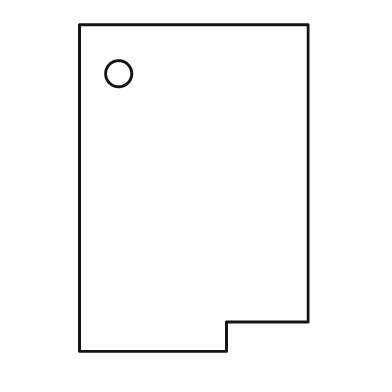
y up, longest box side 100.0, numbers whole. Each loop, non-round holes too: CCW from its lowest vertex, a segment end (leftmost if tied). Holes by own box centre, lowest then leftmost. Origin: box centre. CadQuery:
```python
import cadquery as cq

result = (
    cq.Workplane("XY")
    .moveTo(-35.0, -50.0)
    .lineTo(10.0, -50.0)
    .lineTo(10.0, -41.0)
    .lineTo(35.0, -41.0)
    .lineTo(35.0, 50.0)
    .lineTo(-35.0, 50.0)
    .close()
    .moveTo(-23.0, 35.0)
    .circle(4.0)
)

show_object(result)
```